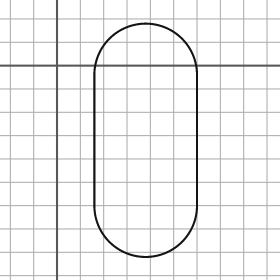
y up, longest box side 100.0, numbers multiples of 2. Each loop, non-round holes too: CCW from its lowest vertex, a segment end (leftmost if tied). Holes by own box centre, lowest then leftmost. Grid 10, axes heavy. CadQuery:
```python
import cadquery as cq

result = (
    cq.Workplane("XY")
    .moveTo(16.0, -60.0)
    .threePointArc((38.0, -82.0), (60.0, -60.0))
    .lineTo(60.0, -4.0)
    .threePointArc((38.0, 18.0), (16.0, -4.0))
    .close()
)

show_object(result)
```